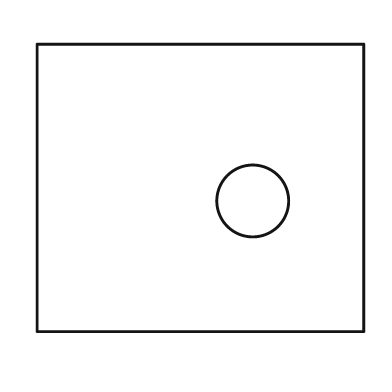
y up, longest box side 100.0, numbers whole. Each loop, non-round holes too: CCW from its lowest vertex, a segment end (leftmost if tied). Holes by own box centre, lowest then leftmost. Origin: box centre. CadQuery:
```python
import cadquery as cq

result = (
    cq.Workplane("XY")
    .moveTo(-50.0, -44.0)
    .lineTo(50.0, -44.0)
    .lineTo(50.0, 44.0)
    .lineTo(-50.0, 44.0)
    .close()
    .moveTo(16.0, -4.0)
    .circle(11.0)
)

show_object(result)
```